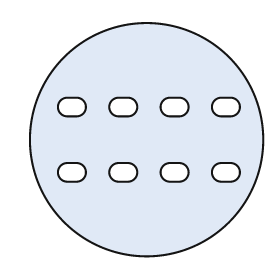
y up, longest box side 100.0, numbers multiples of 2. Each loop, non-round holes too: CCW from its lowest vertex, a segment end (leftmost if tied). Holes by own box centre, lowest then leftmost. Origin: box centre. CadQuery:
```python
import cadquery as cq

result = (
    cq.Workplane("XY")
    .moveTo(0.0, 0.0)
    .circle(50.0)
    .moveTo(-34.0, -18.0)
    .lineTo(-30.0, -18.0)
    .threePointArc((-26.0, -14.0), (-30.0, -10.0))
    .lineTo(-34.0, -10.0)
    .threePointArc((-38.0, -14.0), (-34.0, -18.0))
    .close()
    .moveTo(-12.0, -18.0)
    .lineTo(-8.0, -18.0)
    .threePointArc((-4.0, -14.0), (-8.0, -10.0))
    .lineTo(-12.0, -10.0)
    .threePointArc((-16.0, -14.0), (-12.0, -18.0))
    .close()
    .moveTo(10.0, -18.0)
    .lineTo(14.0, -18.0)
    .threePointArc((18.0, -14.0), (14.0, -10.0))
    .lineTo(10.0, -10.0)
    .threePointArc((6.0, -14.0), (10.0, -18.0))
    .close()
    .moveTo(32.0, -18.0)
    .lineTo(36.0, -18.0)
    .threePointArc((40.0, -14.0), (36.0, -10.0))
    .lineTo(32.0, -10.0)
    .threePointArc((28.0, -14.0), (32.0, -18.0))
    .close()
    .moveTo(-34.0, 10.0)
    .lineTo(-30.0, 10.0)
    .threePointArc((-26.0, 14.0), (-30.0, 18.0))
    .lineTo(-34.0, 18.0)
    .threePointArc((-38.0, 14.0), (-34.0, 10.0))
    .close()
    .moveTo(-12.0, 10.0)
    .lineTo(-8.0, 10.0)
    .threePointArc((-4.0, 14.0), (-8.0, 18.0))
    .lineTo(-12.0, 18.0)
    .threePointArc((-16.0, 14.0), (-12.0, 10.0))
    .close()
    .moveTo(10.0, 10.0)
    .lineTo(14.0, 10.0)
    .threePointArc((18.0, 14.0), (14.0, 18.0))
    .lineTo(10.0, 18.0)
    .threePointArc((6.0, 14.0), (10.0, 10.0))
    .close()
    .moveTo(32.0, 10.0)
    .lineTo(36.0, 10.0)
    .threePointArc((40.0, 14.0), (36.0, 18.0))
    .lineTo(32.0, 18.0)
    .threePointArc((28.0, 14.0), (32.0, 10.0))
    .close()
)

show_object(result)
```